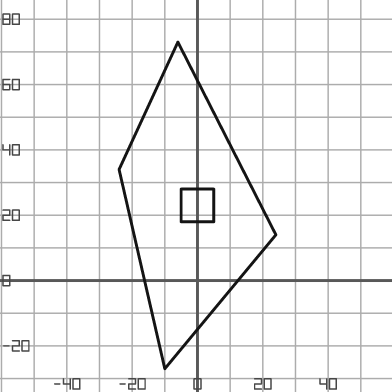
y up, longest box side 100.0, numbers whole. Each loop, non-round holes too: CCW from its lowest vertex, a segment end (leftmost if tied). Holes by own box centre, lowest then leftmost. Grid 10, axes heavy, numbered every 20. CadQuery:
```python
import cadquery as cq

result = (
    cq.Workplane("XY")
    .moveTo(-10.0, -27.0)
    .lineTo(24.0, 14.0)
    .lineTo(-6.0, 73.0)
    .lineTo(-24.0, 34.0)
    .close()
    .moveTo(-5.0, 18.0)
    .lineTo(5.0, 18.0)
    .lineTo(5.0, 28.0)
    .lineTo(-5.0, 28.0)
    .close()
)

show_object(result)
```